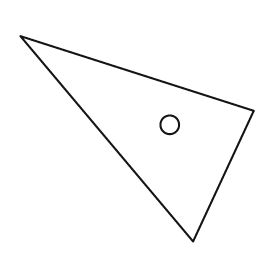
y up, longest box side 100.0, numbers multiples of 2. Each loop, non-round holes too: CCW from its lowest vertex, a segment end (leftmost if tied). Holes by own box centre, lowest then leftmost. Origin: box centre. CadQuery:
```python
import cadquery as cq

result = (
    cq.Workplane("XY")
    .moveTo(24.0, -44.0)
    .lineTo(50.0, 12.0)
    .lineTo(-50.0, 44.0)
    .close()
    .moveTo(14.0, 6.0)
    .circle(4.0)
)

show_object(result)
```